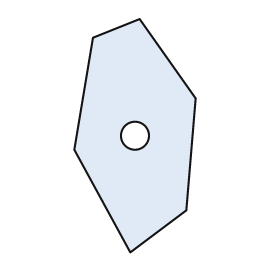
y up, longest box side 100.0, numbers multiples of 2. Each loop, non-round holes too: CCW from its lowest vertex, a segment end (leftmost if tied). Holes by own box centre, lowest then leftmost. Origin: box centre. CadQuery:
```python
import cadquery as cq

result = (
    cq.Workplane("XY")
    .moveTo(-2.0, -50.0)
    .lineTo(22.0, -32.0)
    .lineTo(26.0, 16.0)
    .lineTo(2.0, 50.0)
    .lineTo(-18.0, 42.0)
    .lineTo(-26.0, -6.0)
    .close()
    .moveTo(0.0, 0.0)
    .circle(6.0)
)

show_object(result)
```